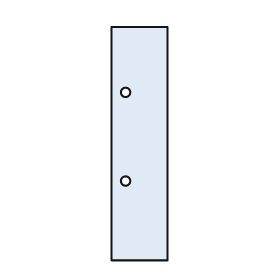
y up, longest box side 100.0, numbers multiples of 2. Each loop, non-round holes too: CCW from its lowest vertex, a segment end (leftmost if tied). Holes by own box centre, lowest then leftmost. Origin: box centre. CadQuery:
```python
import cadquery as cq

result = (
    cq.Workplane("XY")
    .moveTo(-12.0, -50.0)
    .lineTo(12.0, -50.0)
    .lineTo(12.0, 50.0)
    .lineTo(-12.0, 50.0)
    .close()
    .moveTo(-6.0, -16.0)
    .circle(2.0)
    .moveTo(-6.0, 22.0)
    .circle(2.0)
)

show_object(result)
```